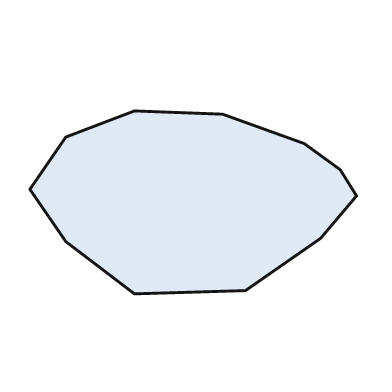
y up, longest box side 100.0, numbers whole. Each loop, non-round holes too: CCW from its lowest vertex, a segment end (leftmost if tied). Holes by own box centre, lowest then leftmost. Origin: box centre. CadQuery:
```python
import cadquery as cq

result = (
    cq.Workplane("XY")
    .moveTo(-18.0, -28.0)
    .lineTo(16.0, -27.0)
    .lineTo(39.0, -11.0)
    .lineTo(50.0, 2.0)
    .lineTo(45.0, 10.0)
    .lineTo(34.0, 18.0)
    .lineTo(9.0, 27.0)
    .lineTo(-18.0, 28.0)
    .lineTo(-39.0, 20.0)
    .lineTo(-50.0, 4.0)
    .lineTo(-39.0, -12.0)
    .close()
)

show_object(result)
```